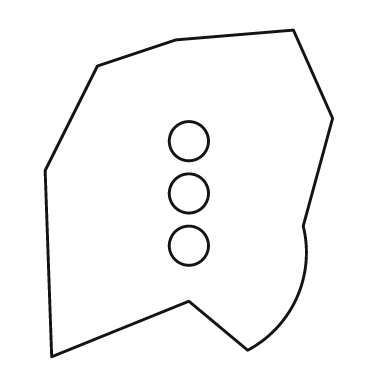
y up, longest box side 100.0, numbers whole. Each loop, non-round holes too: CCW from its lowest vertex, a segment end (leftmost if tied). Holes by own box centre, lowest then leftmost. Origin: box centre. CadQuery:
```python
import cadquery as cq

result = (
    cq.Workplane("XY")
    .moveTo(-42.0, -50.0)
    .lineTo(0.0, -33.0)
    .lineTo(18.0, -48.0)
    .threePointArc((33.0, -32.0), (35.0, -10.0))
    .lineTo(44.0, 23.0)
    .lineTo(32.0, 50.0)
    .lineTo(-4.0, 47.0)
    .lineTo(-28.0, 39.0)
    .lineTo(-44.0, 7.0)
    .close()
    .moveTo(0.0, -16.0)
    .circle(6.0)
    .moveTo(0.0, 0.0)
    .circle(6.0)
    .moveTo(0.0, 16.0)
    .circle(6.0)
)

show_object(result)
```